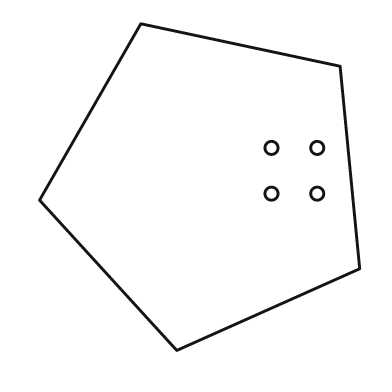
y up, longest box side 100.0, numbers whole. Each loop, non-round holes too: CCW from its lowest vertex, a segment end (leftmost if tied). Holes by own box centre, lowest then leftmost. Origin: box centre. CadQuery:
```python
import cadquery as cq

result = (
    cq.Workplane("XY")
    .moveTo(-7.0, -50.0)
    .lineTo(49.0, -25.0)
    .lineTo(43.0, 37.0)
    .lineTo(-18.0, 50.0)
    .lineTo(-49.0, -4.0)
    .close()
    .moveTo(22.0, -2.0)
    .circle(2.0)
    .moveTo(36.0, -2.0)
    .circle(2.0)
    .moveTo(22.0, 12.0)
    .circle(2.0)
    .moveTo(36.0, 12.0)
    .circle(2.0)
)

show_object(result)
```